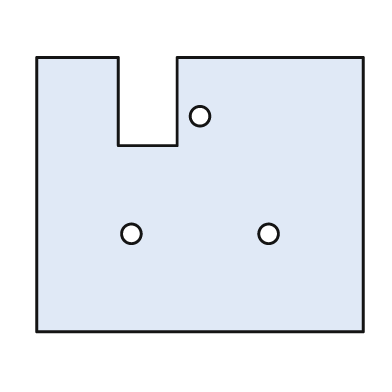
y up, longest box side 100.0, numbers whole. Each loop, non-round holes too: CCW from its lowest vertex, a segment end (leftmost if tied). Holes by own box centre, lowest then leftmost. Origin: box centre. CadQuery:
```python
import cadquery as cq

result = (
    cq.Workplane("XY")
    .moveTo(-50.0, -42.0)
    .lineTo(50.0, -42.0)
    .lineTo(50.0, 42.0)
    .lineTo(-7.0, 42.0)
    .lineTo(-7.0, 15.0)
    .lineTo(-25.0, 15.0)
    .lineTo(-25.0, 42.0)
    .lineTo(-50.0, 42.0)
    .close()
    .moveTo(-21.0, -12.0)
    .circle(3.0)
    .moveTo(21.0, -12.0)
    .circle(3.0)
    .moveTo(0.0, 24.0)
    .circle(3.0)
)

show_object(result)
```